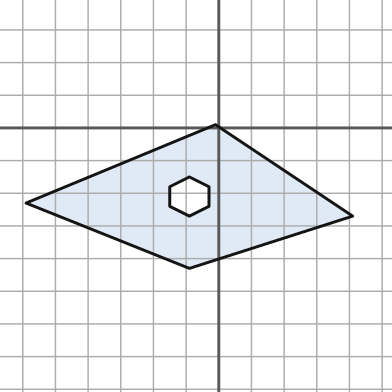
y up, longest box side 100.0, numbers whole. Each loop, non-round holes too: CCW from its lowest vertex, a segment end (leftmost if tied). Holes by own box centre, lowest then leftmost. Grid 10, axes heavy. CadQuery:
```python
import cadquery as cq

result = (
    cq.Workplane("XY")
    .moveTo(-9.0, -43.0)
    .lineTo(41.0, -27.0)
    .lineTo(-1.0, 1.0)
    .lineTo(-59.0, -23.0)
    .close()
    .moveTo(-9.0, -27.0)
    .lineTo(-3.0, -24.0)
    .lineTo(-3.0, -18.0)
    .lineTo(-9.0, -15.0)
    .lineTo(-15.0, -18.0)
    .lineTo(-15.0, -24.0)
    .close()
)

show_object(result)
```